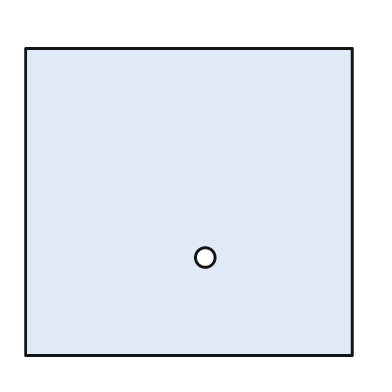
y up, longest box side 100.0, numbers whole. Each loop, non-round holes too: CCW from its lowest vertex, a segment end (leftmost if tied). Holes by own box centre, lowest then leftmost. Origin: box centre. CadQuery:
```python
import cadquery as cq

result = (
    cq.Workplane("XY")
    .moveTo(-50.0, -47.0)
    .lineTo(50.0, -47.0)
    .lineTo(50.0, 47.0)
    .lineTo(-50.0, 47.0)
    .close()
    .moveTo(5.0, -17.0)
    .circle(3.0)
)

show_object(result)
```